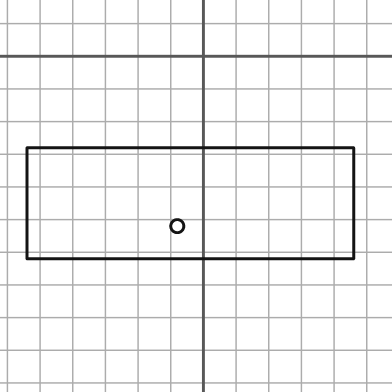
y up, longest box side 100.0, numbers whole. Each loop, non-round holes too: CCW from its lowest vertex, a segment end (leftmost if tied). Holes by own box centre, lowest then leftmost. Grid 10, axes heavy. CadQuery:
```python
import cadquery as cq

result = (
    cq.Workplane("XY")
    .moveTo(-54.0, -62.0)
    .lineTo(46.0, -62.0)
    .lineTo(46.0, -28.0)
    .lineTo(-54.0, -28.0)
    .close()
    .moveTo(-8.0, -52.0)
    .circle(2.0)
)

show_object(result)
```